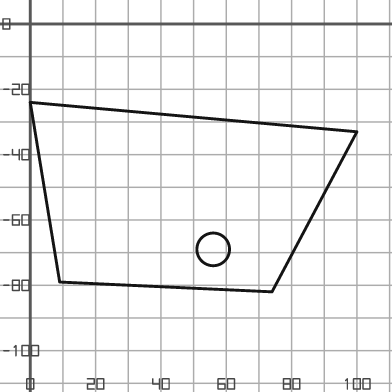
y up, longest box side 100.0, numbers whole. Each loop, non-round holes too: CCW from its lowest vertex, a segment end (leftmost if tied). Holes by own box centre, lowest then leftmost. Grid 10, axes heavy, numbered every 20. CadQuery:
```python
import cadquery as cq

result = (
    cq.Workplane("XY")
    .moveTo(74.0, -82.0)
    .lineTo(100.0, -33.0)
    .lineTo(0.0, -24.0)
    .lineTo(9.0, -79.0)
    .close()
    .moveTo(56.0, -69.0)
    .circle(5.0)
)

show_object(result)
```